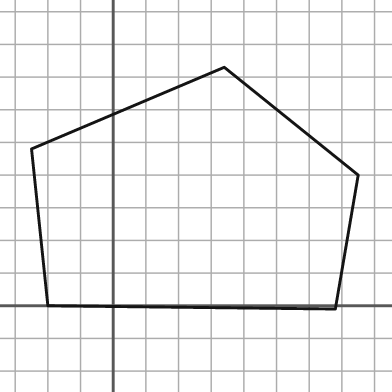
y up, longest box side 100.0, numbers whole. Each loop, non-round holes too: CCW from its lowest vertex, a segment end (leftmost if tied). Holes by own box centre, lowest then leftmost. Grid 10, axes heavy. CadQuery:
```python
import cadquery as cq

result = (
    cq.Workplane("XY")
    .moveTo(68.0, -1.0)
    .lineTo(75.0, 40.0)
    .lineTo(34.0, 73.0)
    .lineTo(-25.0, 48.0)
    .lineTo(-20.0, 0.0)
    .close()
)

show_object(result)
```